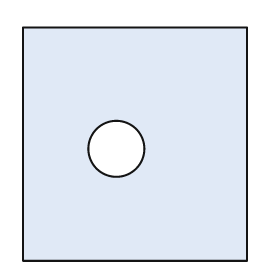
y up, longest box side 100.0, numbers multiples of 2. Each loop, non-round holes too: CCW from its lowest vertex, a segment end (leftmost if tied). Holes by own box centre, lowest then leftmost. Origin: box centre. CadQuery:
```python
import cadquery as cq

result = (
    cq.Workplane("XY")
    .moveTo(-48.0, -50.0)
    .lineTo(48.0, -50.0)
    .lineTo(48.0, 50.0)
    .lineTo(-48.0, 50.0)
    .close()
    .moveTo(-8.0, -2.0)
    .circle(12.0)
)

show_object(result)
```